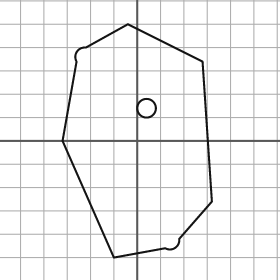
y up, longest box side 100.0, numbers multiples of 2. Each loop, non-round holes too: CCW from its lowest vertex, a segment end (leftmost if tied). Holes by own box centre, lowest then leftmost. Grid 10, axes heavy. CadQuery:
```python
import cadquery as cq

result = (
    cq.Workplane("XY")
    .moveTo(-10.0, -50.0)
    .lineTo(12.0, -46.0)
    .threePointArc((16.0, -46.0), (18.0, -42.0))
    .lineTo(32.0, -26.0)
    .lineTo(28.0, 34.0)
    .lineTo(-4.0, 50.0)
    .lineTo(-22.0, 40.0)
    .threePointArc((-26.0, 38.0), (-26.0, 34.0))
    .lineTo(-32.0, 0.0)
    .close()
    .moveTo(4.0, 14.0)
    .circle(4.0)
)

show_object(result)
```